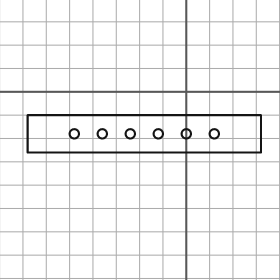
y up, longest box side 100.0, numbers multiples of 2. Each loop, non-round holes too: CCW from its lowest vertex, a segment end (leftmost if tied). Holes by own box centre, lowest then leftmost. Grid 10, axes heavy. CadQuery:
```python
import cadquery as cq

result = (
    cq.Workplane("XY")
    .moveTo(-68.0, -26.0)
    .lineTo(32.0, -26.0)
    .lineTo(32.0, -10.0)
    .lineTo(-68.0, -10.0)
    .close()
    .moveTo(-48.0, -18.0)
    .circle(2.0)
    .moveTo(-36.0, -18.0)
    .circle(2.0)
    .moveTo(-24.0, -18.0)
    .circle(2.0)
    .moveTo(-12.0, -18.0)
    .circle(2.0)
    .moveTo(0.0, -18.0)
    .circle(2.0)
    .moveTo(12.0, -18.0)
    .circle(2.0)
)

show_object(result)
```